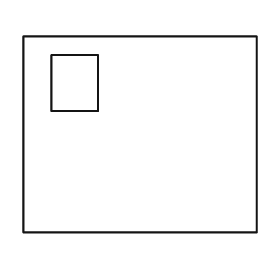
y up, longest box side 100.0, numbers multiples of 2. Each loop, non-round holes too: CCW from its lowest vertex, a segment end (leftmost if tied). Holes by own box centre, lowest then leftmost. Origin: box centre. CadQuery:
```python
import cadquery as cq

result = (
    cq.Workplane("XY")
    .moveTo(-50.0, -42.0)
    .lineTo(50.0, -42.0)
    .lineTo(50.0, 42.0)
    .lineTo(-50.0, 42.0)
    .close()
    .moveTo(-38.0, 10.0)
    .lineTo(-18.0, 10.0)
    .lineTo(-18.0, 34.0)
    .lineTo(-38.0, 34.0)
    .close()
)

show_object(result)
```